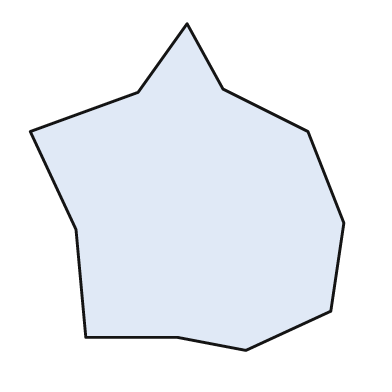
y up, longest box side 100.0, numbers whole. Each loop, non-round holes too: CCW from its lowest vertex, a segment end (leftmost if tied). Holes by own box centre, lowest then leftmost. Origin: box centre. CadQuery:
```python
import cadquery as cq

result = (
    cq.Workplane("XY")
    .moveTo(18.0, -50.0)
    .lineTo(44.0, -38.0)
    .lineTo(48.0, -11.0)
    .lineTo(37.0, 17.0)
    .lineTo(11.0, 30.0)
    .lineTo(0.0, 50.0)
    .lineTo(-15.0, 29.0)
    .lineTo(-48.0, 17.0)
    .lineTo(-34.0, -13.0)
    .lineTo(-31.0, -46.0)
    .lineTo(-3.0, -46.0)
    .close()
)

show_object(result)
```